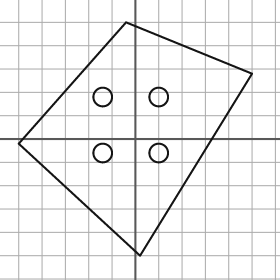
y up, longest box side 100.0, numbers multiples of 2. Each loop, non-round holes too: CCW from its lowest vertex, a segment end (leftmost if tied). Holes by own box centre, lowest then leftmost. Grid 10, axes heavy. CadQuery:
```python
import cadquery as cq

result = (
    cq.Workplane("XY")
    .moveTo(2.0, -50.0)
    .lineTo(50.0, 28.0)
    .lineTo(-4.0, 50.0)
    .lineTo(-50.0, -2.0)
    .close()
    .moveTo(-14.0, -6.0)
    .circle(4.0)
    .moveTo(10.0, -6.0)
    .circle(4.0)
    .moveTo(-14.0, 18.0)
    .circle(4.0)
    .moveTo(10.0, 18.0)
    .circle(4.0)
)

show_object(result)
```